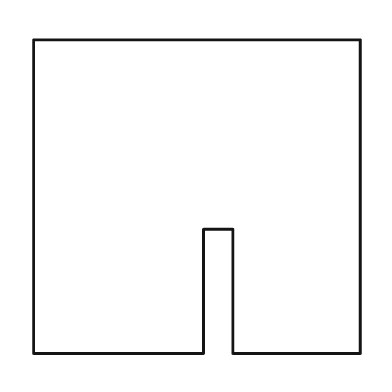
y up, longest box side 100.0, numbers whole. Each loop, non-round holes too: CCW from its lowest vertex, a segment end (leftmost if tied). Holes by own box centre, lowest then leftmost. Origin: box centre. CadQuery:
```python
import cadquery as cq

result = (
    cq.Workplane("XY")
    .moveTo(-50.0, -48.0)
    .lineTo(2.0, -48.0)
    .lineTo(2.0, -10.0)
    .lineTo(11.0, -10.0)
    .lineTo(11.0, -48.0)
    .lineTo(50.0, -48.0)
    .lineTo(50.0, 48.0)
    .lineTo(-50.0, 48.0)
    .close()
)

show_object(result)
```